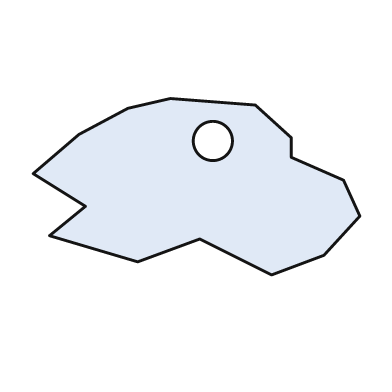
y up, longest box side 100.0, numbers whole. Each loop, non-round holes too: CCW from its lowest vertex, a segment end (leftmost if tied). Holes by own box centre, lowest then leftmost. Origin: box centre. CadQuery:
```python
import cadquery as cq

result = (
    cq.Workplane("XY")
    .moveTo(23.0, -27.0)
    .lineTo(39.0, -21.0)
    .lineTo(50.0, -9.0)
    .lineTo(45.0, 2.0)
    .lineTo(29.0, 9.0)
    .lineTo(29.0, 15.0)
    .lineTo(18.0, 25.0)
    .lineTo(-8.0, 27.0)
    .lineTo(-21.0, 24.0)
    .lineTo(-36.0, 16.0)
    .lineTo(-50.0, 4.0)
    .lineTo(-34.0, -6.0)
    .lineTo(-45.0, -15.0)
    .lineTo(-18.0, -23.0)
    .lineTo(1.0, -16.0)
    .close()
    .moveTo(5.0, 14.0)
    .circle(6.0)
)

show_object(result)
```